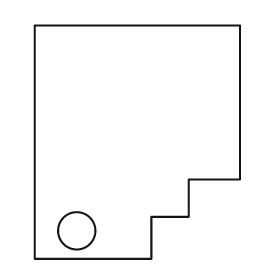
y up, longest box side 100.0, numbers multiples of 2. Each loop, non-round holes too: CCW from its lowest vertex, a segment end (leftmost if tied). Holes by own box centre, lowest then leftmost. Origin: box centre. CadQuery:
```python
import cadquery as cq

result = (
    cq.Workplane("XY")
    .moveTo(-44.0, -50.0)
    .lineTo(6.0, -50.0)
    .lineTo(6.0, -32.0)
    .lineTo(22.0, -32.0)
    .lineTo(22.0, -16.0)
    .lineTo(44.0, -16.0)
    .lineTo(44.0, 50.0)
    .lineTo(-44.0, 50.0)
    .close()
    .moveTo(-26.0, -38.0)
    .circle(8.0)
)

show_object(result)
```